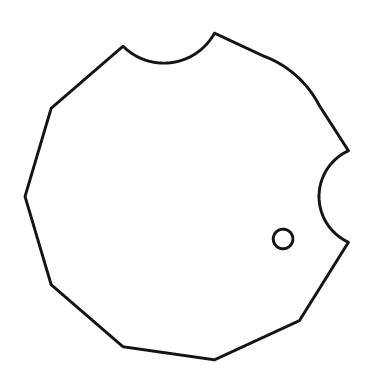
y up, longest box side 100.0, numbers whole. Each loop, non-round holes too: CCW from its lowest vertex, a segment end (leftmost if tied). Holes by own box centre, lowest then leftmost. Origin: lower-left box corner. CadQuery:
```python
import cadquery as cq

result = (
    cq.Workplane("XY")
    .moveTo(58.0, 0.0)
    .lineTo(84.0, 12.0)
    .lineTo(99.0, 36.0)
    .threePointArc((90.0, 50.0), (99.0, 64.0))
    .lineTo(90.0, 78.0)
    .threePointArc((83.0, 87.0), (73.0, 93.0))
    .lineTo(58.0, 100.0)
    .threePointArc((45.0, 91.0), (30.0, 96.0))
    .lineTo(8.0, 77.0)
    .lineTo(0.0, 50.0)
    .lineTo(8.0, 23.0)
    .lineTo(30.0, 4.0)
    .close()
    .moveTo(79.0, 37.0)
    .circle(3.0)
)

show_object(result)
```